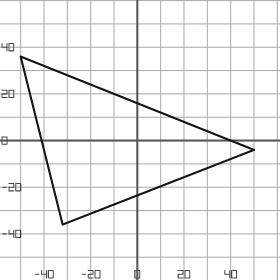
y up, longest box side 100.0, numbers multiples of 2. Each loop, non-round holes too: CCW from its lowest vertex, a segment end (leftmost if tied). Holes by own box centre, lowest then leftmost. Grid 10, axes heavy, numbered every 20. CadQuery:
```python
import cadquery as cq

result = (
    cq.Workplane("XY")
    .moveTo(-32.0, -36.0)
    .lineTo(50.0, -4.0)
    .lineTo(-50.0, 36.0)
    .close()
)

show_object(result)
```